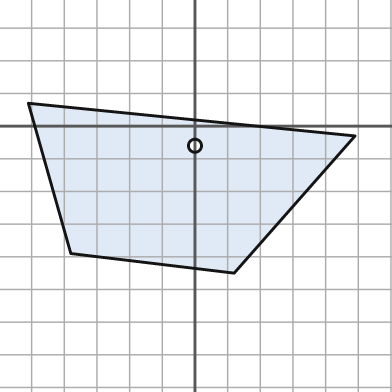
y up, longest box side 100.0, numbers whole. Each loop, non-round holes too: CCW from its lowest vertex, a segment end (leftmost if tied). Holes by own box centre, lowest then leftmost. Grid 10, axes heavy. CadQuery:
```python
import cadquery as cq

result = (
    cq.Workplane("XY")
    .moveTo(12.0, -45.0)
    .lineTo(49.0, -3.0)
    .lineTo(-51.0, 7.0)
    .lineTo(-38.0, -39.0)
    .close()
    .moveTo(0.0, -6.0)
    .circle(2.0)
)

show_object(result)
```